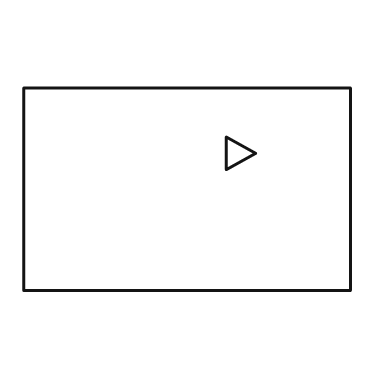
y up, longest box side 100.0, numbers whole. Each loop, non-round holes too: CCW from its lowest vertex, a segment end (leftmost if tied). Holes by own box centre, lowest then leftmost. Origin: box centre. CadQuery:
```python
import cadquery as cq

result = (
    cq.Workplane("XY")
    .moveTo(-50.0, -31.0)
    .lineTo(50.0, -31.0)
    .lineTo(50.0, 31.0)
    .lineTo(-50.0, 31.0)
    .close()
    .moveTo(12.0, 6.0)
    .lineTo(21.0, 11.0)
    .lineTo(12.0, 16.0)
    .close()
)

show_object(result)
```